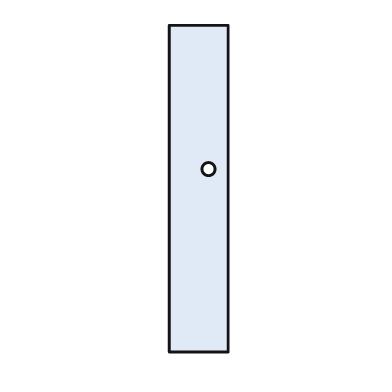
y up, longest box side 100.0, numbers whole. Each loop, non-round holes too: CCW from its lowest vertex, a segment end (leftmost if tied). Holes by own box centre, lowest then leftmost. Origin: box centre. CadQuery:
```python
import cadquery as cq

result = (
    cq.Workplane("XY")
    .moveTo(-9.0, -50.0)
    .lineTo(9.0, -50.0)
    .lineTo(9.0, 50.0)
    .lineTo(-9.0, 50.0)
    .close()
    .moveTo(3.0, 6.0)
    .circle(2.0)
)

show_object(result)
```